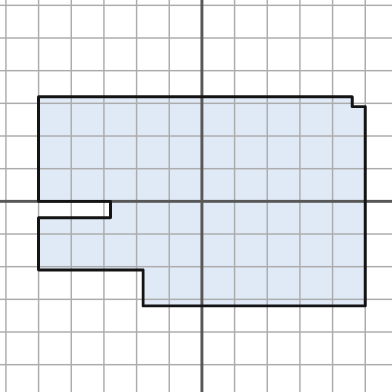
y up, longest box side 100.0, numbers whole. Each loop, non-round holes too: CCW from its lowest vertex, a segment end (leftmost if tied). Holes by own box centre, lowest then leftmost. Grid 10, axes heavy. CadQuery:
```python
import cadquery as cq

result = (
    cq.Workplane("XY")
    .moveTo(-18.0, -32.0)
    .lineTo(50.0, -32.0)
    .lineTo(50.0, 29.0)
    .lineTo(46.0, 29.0)
    .lineTo(46.0, 32.0)
    .lineTo(-50.0, 32.0)
    .lineTo(-50.0, 0.0)
    .lineTo(-28.0, 0.0)
    .lineTo(-28.0, -5.0)
    .lineTo(-50.0, -5.0)
    .lineTo(-50.0, -21.0)
    .lineTo(-18.0, -21.0)
    .close()
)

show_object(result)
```